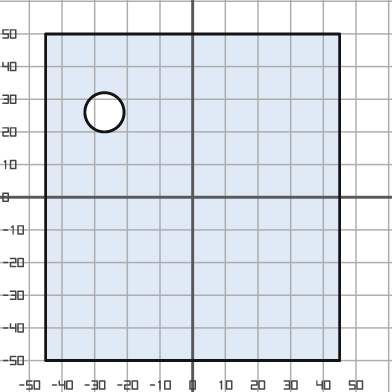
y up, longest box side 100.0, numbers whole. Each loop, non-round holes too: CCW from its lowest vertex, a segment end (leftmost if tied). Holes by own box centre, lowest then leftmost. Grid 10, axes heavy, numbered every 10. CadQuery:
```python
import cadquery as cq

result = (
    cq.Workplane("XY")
    .moveTo(-45.0, -50.0)
    .lineTo(45.0, -50.0)
    .lineTo(45.0, 50.0)
    .lineTo(-45.0, 50.0)
    .close()
    .moveTo(-27.0, 26.0)
    .circle(6.0)
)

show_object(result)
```